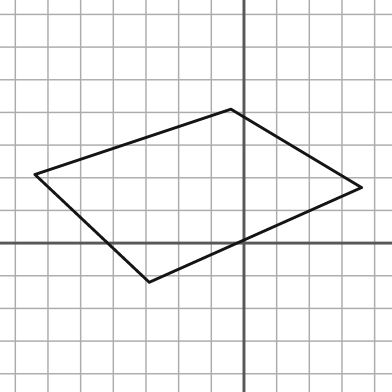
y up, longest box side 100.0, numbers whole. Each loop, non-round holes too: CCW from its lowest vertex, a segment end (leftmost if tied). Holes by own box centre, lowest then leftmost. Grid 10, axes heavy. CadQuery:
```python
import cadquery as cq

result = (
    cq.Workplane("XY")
    .moveTo(-29.0, -12.0)
    .lineTo(36.0, 17.0)
    .lineTo(-4.0, 41.0)
    .lineTo(-64.0, 21.0)
    .close()
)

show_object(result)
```